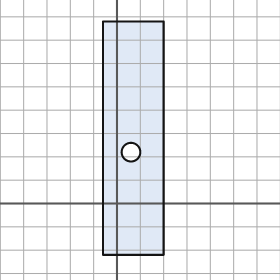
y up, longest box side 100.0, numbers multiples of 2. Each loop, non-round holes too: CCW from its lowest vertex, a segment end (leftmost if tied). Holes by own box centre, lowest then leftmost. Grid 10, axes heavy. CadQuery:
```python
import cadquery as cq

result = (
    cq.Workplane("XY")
    .moveTo(-6.0, -22.0)
    .lineTo(20.0, -22.0)
    .lineTo(20.0, 78.0)
    .lineTo(-6.0, 78.0)
    .close()
    .moveTo(6.0, 22.0)
    .circle(4.0)
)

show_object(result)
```